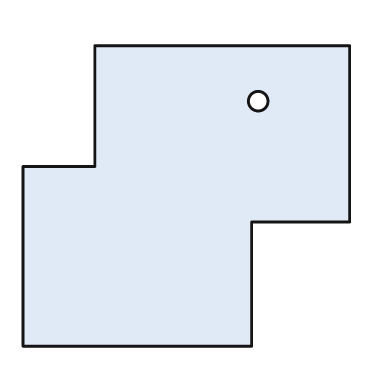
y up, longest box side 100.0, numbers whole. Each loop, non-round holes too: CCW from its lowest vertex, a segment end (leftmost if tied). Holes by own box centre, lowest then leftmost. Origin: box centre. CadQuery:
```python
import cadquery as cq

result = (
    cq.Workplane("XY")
    .moveTo(-50.0, -46.0)
    .lineTo(20.0, -46.0)
    .lineTo(20.0, -8.0)
    .lineTo(50.0, -8.0)
    .lineTo(50.0, 46.0)
    .lineTo(-28.0, 46.0)
    .lineTo(-28.0, 9.0)
    .lineTo(-50.0, 9.0)
    .close()
    .moveTo(22.0, 29.0)
    .circle(3.0)
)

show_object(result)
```